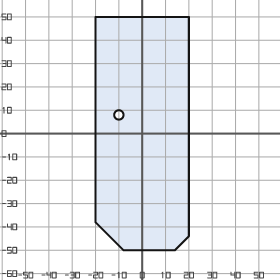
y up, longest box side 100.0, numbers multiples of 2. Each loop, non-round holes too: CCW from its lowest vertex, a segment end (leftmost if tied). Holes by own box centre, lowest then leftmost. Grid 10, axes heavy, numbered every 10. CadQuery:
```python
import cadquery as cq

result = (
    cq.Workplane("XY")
    .moveTo(-8.0, -50.0)
    .lineTo(14.0, -50.0)
    .lineTo(20.0, -44.0)
    .lineTo(20.0, 50.0)
    .lineTo(-20.0, 50.0)
    .lineTo(-20.0, -38.0)
    .close()
    .moveTo(-10.0, 8.0)
    .circle(2.0)
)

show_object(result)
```